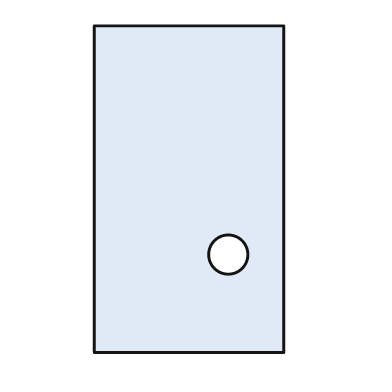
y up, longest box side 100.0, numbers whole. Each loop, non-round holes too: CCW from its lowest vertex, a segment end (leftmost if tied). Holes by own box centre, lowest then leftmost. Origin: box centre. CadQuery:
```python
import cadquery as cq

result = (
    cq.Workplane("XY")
    .moveTo(-29.0, -50.0)
    .lineTo(29.0, -50.0)
    .lineTo(29.0, 50.0)
    .lineTo(-29.0, 50.0)
    .close()
    .moveTo(12.0, -20.0)
    .circle(6.0)
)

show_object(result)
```